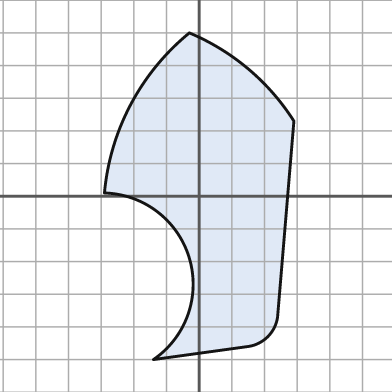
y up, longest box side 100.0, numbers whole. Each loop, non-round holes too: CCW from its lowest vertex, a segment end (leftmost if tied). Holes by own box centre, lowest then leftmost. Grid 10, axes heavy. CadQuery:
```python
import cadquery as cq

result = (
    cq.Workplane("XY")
    .moveTo(-14.0, -50.0)
    .lineTo(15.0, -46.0)
    .threePointArc((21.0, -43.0), (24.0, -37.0))
    .lineTo(29.0, 23.0)
    .threePointArc((15.0, 39.0), (-3.0, 50.0))
    .threePointArc((-21.0, 28.0), (-29.0, 1.0))
    .threePointArc((-3.0, -19.0), (-14.0, -50.0))
    .close()
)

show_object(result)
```